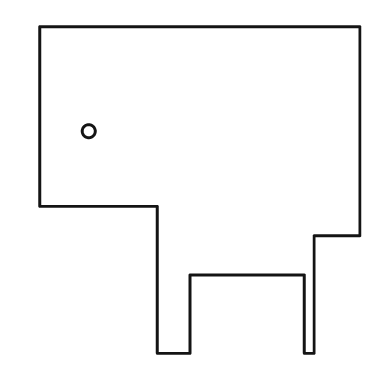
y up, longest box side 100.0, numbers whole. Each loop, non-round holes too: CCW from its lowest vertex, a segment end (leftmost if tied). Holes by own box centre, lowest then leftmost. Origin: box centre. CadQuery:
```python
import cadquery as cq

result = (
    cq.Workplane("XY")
    .moveTo(-13.0, -50.0)
    .lineTo(-3.0, -50.0)
    .lineTo(-3.0, -26.0)
    .lineTo(32.0, -26.0)
    .lineTo(32.0, -50.0)
    .lineTo(35.0, -50.0)
    .lineTo(35.0, -14.0)
    .lineTo(49.0, -14.0)
    .lineTo(49.0, 50.0)
    .lineTo(-49.0, 50.0)
    .lineTo(-49.0, -5.0)
    .lineTo(-13.0, -5.0)
    .close()
    .moveTo(-34.0, 18.0)
    .circle(2.0)
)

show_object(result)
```